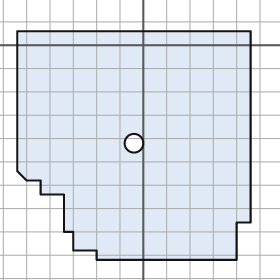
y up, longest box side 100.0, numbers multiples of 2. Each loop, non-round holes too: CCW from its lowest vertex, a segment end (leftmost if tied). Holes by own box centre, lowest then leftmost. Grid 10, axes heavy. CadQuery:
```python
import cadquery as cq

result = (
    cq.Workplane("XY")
    .moveTo(-20.0, -92.0)
    .lineTo(40.0, -92.0)
    .lineTo(40.0, -76.0)
    .lineTo(46.0, -76.0)
    .lineTo(46.0, 6.0)
    .lineTo(-54.0, 6.0)
    .lineTo(-54.0, -54.0)
    .lineTo(-50.0, -58.0)
    .lineTo(-44.0, -58.0)
    .lineTo(-44.0, -64.0)
    .lineTo(-34.0, -64.0)
    .lineTo(-34.0, -80.0)
    .lineTo(-30.0, -80.0)
    .lineTo(-30.0, -88.0)
    .lineTo(-20.0, -88.0)
    .close()
    .moveTo(-4.0, -42.0)
    .circle(4.0)
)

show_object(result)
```